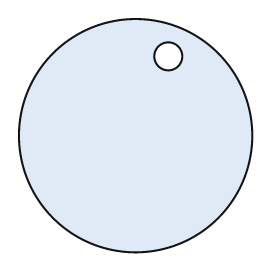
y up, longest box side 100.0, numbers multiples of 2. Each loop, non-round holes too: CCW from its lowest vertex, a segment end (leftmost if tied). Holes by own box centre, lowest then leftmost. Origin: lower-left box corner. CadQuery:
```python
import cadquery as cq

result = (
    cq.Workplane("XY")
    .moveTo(50.0, 50.0)
    .circle(50.0)
    .moveTo(64.0, 84.0)
    .circle(6.0)
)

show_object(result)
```